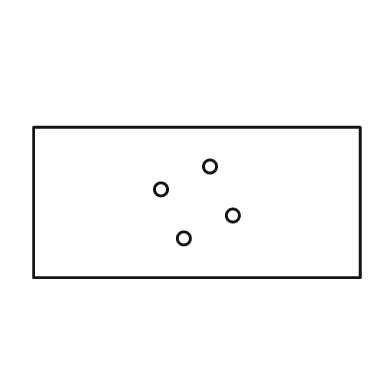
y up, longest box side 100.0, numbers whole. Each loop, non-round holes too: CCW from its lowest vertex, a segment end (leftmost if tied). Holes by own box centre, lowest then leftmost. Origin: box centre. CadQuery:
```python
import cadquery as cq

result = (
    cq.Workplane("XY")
    .moveTo(-50.0, -23.0)
    .lineTo(50.0, -23.0)
    .lineTo(50.0, 23.0)
    .lineTo(-50.0, 23.0)
    .close()
    .moveTo(-4.0, -11.0)
    .circle(2.0)
    .moveTo(11.0, -4.0)
    .circle(2.0)
    .moveTo(-11.0, 4.0)
    .circle(2.0)
    .moveTo(4.0, 11.0)
    .circle(2.0)
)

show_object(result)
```